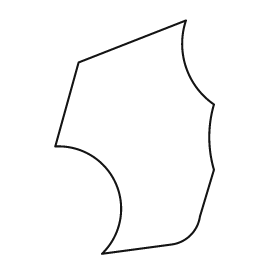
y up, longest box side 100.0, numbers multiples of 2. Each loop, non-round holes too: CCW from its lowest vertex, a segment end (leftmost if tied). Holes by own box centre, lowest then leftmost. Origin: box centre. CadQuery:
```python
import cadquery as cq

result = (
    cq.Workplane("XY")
    .moveTo(-14.0, -50.0)
    .lineTo(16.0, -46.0)
    .threePointArc((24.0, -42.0), (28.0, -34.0))
    .lineTo(34.0, -14.0)
    .threePointArc((32.0, 0.0), (34.0, 14.0))
    .threePointArc((22.0, 30.0), (22.0, 50.0))
    .lineTo(-24.0, 32.0)
    .lineTo(-34.0, -4.0)
    .threePointArc((-8.0, -20.0), (-14.0, -50.0))
    .close()
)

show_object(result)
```